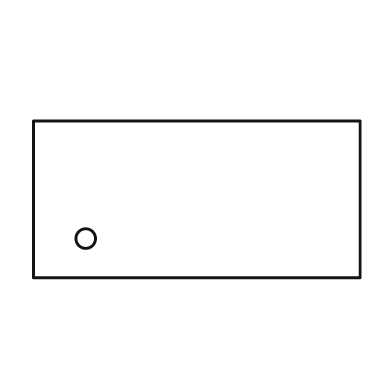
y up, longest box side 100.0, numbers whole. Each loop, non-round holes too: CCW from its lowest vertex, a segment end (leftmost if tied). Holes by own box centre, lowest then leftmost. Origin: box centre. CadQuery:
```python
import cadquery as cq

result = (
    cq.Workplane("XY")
    .moveTo(-50.0, -24.0)
    .lineTo(50.0, -24.0)
    .lineTo(50.0, 24.0)
    .lineTo(-50.0, 24.0)
    .close()
    .moveTo(-34.0, -12.0)
    .circle(3.0)
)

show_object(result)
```